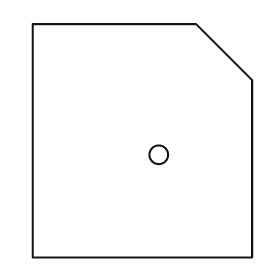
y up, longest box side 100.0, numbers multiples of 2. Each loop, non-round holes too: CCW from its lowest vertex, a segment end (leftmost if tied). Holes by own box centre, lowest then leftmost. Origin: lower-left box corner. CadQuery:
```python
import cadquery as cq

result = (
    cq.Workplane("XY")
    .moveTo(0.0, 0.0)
    .lineTo(94.0, 0.0)
    .lineTo(94.0, 76.0)
    .lineTo(70.0, 100.0)
    .lineTo(0.0, 100.0)
    .close()
    .moveTo(54.0, 44.0)
    .circle(4.0)
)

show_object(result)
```